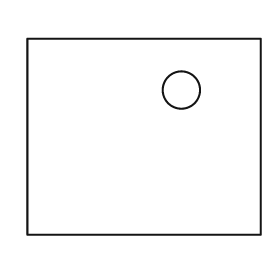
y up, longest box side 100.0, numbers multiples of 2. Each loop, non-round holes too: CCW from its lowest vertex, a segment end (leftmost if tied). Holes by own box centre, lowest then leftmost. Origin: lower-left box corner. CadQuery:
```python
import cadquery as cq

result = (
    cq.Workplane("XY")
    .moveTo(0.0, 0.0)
    .lineTo(100.0, 0.0)
    .lineTo(100.0, 84.0)
    .lineTo(0.0, 84.0)
    .close()
    .moveTo(66.0, 62.0)
    .circle(8.0)
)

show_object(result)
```